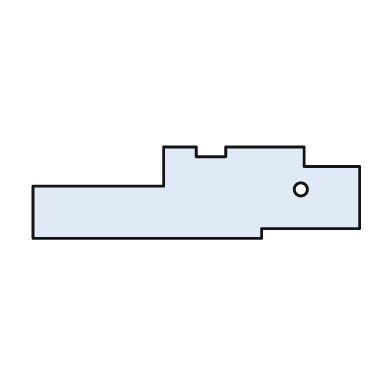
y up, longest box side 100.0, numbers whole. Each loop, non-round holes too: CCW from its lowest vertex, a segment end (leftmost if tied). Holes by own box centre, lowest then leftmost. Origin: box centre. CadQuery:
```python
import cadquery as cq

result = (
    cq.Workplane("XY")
    .moveTo(-50.0, -14.0)
    .lineTo(20.0, -14.0)
    .lineTo(20.0, -11.0)
    .lineTo(50.0, -11.0)
    .lineTo(50.0, 8.0)
    .lineTo(33.0, 8.0)
    .lineTo(33.0, 14.0)
    .lineTo(9.0, 14.0)
    .lineTo(9.0, 11.0)
    .lineTo(0.0, 11.0)
    .lineTo(0.0, 14.0)
    .lineTo(-10.0, 14.0)
    .lineTo(-10.0, 2.0)
    .lineTo(-50.0, 2.0)
    .close()
    .moveTo(32.0, 1.0)
    .circle(2.0)
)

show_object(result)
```